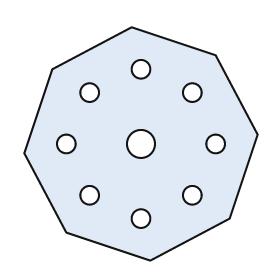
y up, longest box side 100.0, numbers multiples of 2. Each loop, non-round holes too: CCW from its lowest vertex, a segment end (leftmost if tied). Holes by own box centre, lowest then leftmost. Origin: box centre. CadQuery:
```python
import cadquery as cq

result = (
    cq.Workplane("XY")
    .moveTo(4.0, -50.0)
    .lineTo(38.0, -32.0)
    .lineTo(50.0, 4.0)
    .lineTo(32.0, 38.0)
    .lineTo(-4.0, 50.0)
    .lineTo(-38.0, 32.0)
    .lineTo(-50.0, -4.0)
    .lineTo(-32.0, -38.0)
    .close()
    .moveTo(0.0, -32.0)
    .circle(4.0)
    .moveTo(-22.0, -22.0)
    .circle(4.0)
    .moveTo(22.0, -22.0)
    .circle(4.0)
    .moveTo(-32.0, 0.0)
    .circle(4.0)
    .moveTo(0.0, 0.0)
    .circle(6.0)
    .moveTo(32.0, 0.0)
    .circle(4.0)
    .moveTo(-22.0, 22.0)
    .circle(4.0)
    .moveTo(22.0, 22.0)
    .circle(4.0)
    .moveTo(0.0, 32.0)
    .circle(4.0)
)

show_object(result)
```